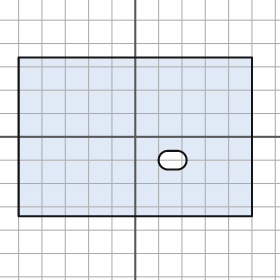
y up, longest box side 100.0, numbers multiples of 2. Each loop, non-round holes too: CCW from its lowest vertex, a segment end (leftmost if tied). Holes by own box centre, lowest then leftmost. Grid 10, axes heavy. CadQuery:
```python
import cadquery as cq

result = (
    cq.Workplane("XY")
    .moveTo(-50.0, -34.0)
    .lineTo(50.0, -34.0)
    .lineTo(50.0, 34.0)
    .lineTo(-50.0, 34.0)
    .close()
    .moveTo(14.0, -14.0)
    .lineTo(18.0, -14.0)
    .threePointArc((22.0, -10.0), (18.0, -6.0))
    .lineTo(14.0, -6.0)
    .threePointArc((10.0, -10.0), (14.0, -14.0))
    .close()
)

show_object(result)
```